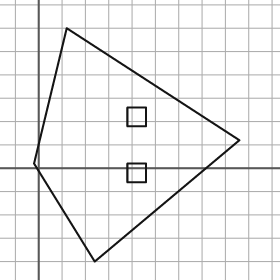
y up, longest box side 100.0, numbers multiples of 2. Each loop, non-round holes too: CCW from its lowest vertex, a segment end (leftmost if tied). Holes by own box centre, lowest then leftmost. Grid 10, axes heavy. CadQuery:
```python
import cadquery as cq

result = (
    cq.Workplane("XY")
    .moveTo(24.0, -40.0)
    .lineTo(86.0, 12.0)
    .lineTo(12.0, 60.0)
    .lineTo(-2.0, 2.0)
    .close()
    .moveTo(38.0, -6.0)
    .lineTo(46.0, -6.0)
    .lineTo(46.0, 2.0)
    .lineTo(38.0, 2.0)
    .close()
    .moveTo(38.0, 18.0)
    .lineTo(46.0, 18.0)
    .lineTo(46.0, 26.0)
    .lineTo(38.0, 26.0)
    .close()
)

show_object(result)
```